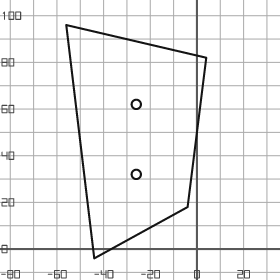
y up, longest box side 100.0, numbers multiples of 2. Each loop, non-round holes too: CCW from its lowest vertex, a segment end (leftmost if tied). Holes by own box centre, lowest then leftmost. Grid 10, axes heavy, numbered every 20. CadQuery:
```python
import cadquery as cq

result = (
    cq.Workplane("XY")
    .moveTo(-44.0, -4.0)
    .lineTo(-4.0, 18.0)
    .lineTo(4.0, 82.0)
    .lineTo(-56.0, 96.0)
    .close()
    .moveTo(-26.0, 32.0)
    .circle(2.0)
    .moveTo(-26.0, 62.0)
    .circle(2.0)
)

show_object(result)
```